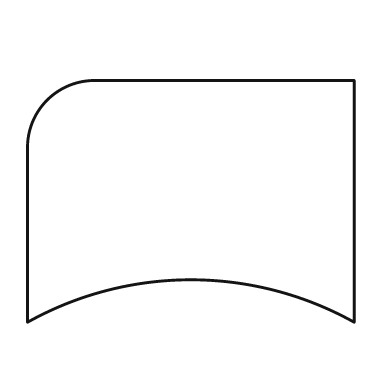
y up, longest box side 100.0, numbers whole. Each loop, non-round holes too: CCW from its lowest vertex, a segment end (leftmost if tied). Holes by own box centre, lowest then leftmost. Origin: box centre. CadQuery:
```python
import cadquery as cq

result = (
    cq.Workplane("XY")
    .moveTo(-50.0, -37.0)
    .threePointArc((0.0, -24.0), (50.0, -37.0))
    .lineTo(50.0, 37.0)
    .lineTo(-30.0, 37.0)
    .threePointArc((-44.0, 31.0), (-50.0, 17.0))
    .close()
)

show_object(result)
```